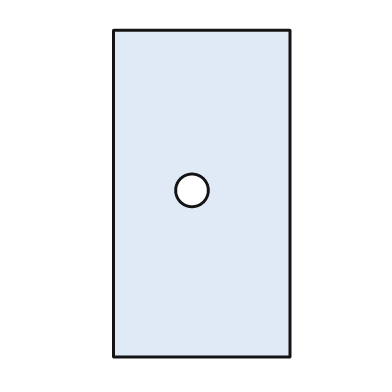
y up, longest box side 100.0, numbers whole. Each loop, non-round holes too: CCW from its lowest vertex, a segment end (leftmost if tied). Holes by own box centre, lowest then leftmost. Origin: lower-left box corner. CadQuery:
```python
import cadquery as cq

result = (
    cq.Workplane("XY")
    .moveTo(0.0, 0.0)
    .lineTo(54.0, 0.0)
    .lineTo(54.0, 100.0)
    .lineTo(0.0, 100.0)
    .close()
    .moveTo(24.0, 51.0)
    .circle(5.0)
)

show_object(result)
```